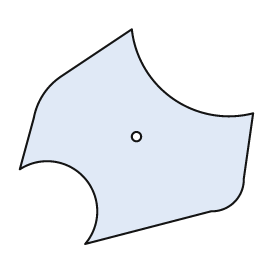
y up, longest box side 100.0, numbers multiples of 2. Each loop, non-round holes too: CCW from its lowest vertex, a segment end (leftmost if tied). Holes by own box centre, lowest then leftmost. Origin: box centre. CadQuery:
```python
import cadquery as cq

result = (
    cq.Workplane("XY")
    .moveTo(-22.0, -46.0)
    .lineTo(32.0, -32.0)
    .threePointArc((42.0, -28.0), (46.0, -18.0))
    .lineTo(50.0, 10.0)
    .threePointArc((16.0, 16.0), (-2.0, 46.0))
    .lineTo(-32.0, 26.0)
    .threePointArc((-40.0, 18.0), (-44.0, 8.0))
    .lineTo(-50.0, -14.0)
    .threePointArc((-22.0, -18.0), (-22.0, -46.0))
    .close()
    .moveTo(0.0, 0.0)
    .circle(2.0)
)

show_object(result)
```